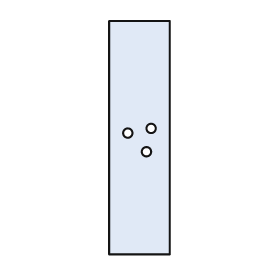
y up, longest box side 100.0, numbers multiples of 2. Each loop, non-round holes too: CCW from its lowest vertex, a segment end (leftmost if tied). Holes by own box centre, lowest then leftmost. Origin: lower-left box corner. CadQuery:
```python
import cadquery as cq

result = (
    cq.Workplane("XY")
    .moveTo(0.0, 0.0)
    .lineTo(26.0, 0.0)
    .lineTo(26.0, 100.0)
    .lineTo(0.0, 100.0)
    .close()
    .moveTo(16.0, 44.0)
    .circle(2.0)
    .moveTo(8.0, 52.0)
    .circle(2.0)
    .moveTo(18.0, 54.0)
    .circle(2.0)
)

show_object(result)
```